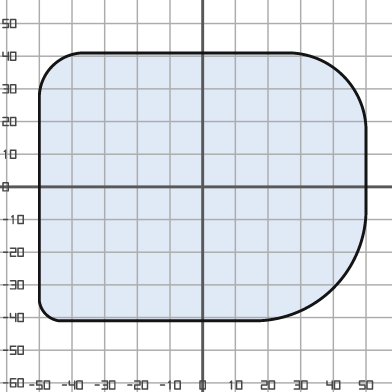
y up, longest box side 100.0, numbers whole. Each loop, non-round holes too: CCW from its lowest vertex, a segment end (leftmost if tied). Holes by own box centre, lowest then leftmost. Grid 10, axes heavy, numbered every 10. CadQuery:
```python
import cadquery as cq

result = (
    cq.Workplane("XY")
    .moveTo(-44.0, -41.0)
    .lineTo(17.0, -41.0)
    .threePointArc((40.0, -31.0), (50.0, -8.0))
    .lineTo(50.0, 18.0)
    .threePointArc((43.0, 34.0), (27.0, 41.0))
    .lineTo(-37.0, 41.0)
    .threePointArc((-46.0, 37.0), (-50.0, 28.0))
    .lineTo(-50.0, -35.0)
    .threePointArc((-48.0, -39.0), (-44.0, -41.0))
    .close()
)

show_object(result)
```